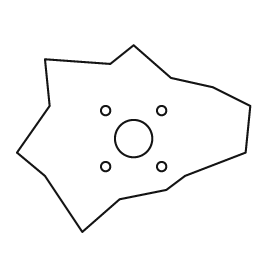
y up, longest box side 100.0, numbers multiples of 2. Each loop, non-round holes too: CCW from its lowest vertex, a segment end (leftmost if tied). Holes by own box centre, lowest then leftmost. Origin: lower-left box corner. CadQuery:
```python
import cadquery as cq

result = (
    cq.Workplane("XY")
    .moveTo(28.0, 0.0)
    .lineTo(44.0, 14.0)
    .lineTo(64.0, 18.0)
    .lineTo(72.0, 24.0)
    .lineTo(98.0, 34.0)
    .lineTo(100.0, 54.0)
    .lineTo(84.0, 62.0)
    .lineTo(66.0, 66.0)
    .lineTo(50.0, 80.0)
    .lineTo(40.0, 72.0)
    .lineTo(12.0, 74.0)
    .lineTo(14.0, 54.0)
    .lineTo(0.0, 34.0)
    .lineTo(12.0, 24.0)
    .close()
    .moveTo(38.0, 28.0)
    .circle(2.0)
    .moveTo(62.0, 28.0)
    .circle(2.0)
    .moveTo(50.0, 40.0)
    .circle(8.0)
    .moveTo(38.0, 52.0)
    .circle(2.0)
    .moveTo(62.0, 52.0)
    .circle(2.0)
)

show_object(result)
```